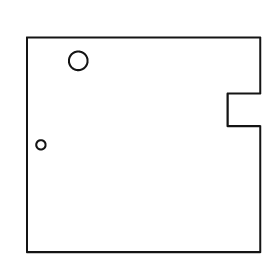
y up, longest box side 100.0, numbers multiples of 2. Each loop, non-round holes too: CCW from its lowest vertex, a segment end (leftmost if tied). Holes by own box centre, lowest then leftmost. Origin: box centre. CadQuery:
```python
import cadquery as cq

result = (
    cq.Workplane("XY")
    .moveTo(-50.0, -46.0)
    .lineTo(50.0, -46.0)
    .lineTo(50.0, 8.0)
    .lineTo(36.0, 8.0)
    .lineTo(36.0, 22.0)
    .lineTo(50.0, 22.0)
    .lineTo(50.0, 46.0)
    .lineTo(-50.0, 46.0)
    .close()
    .moveTo(-44.0, 0.0)
    .circle(2.0)
    .moveTo(-28.0, 36.0)
    .circle(4.0)
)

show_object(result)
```